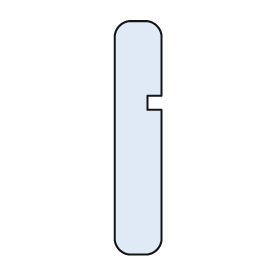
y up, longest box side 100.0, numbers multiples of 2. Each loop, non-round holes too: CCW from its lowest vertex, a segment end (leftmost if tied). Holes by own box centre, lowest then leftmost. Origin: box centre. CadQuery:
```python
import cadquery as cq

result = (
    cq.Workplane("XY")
    .moveTo(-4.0, -50.0)
    .lineTo(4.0, -50.0)
    .threePointArc((8.0, -48.0), (10.0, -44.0))
    .lineTo(10.0, 12.0)
    .lineTo(4.0, 12.0)
    .lineTo(4.0, 18.0)
    .lineTo(10.0, 18.0)
    .lineTo(10.0, 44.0)
    .threePointArc((8.0, 48.0), (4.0, 50.0))
    .lineTo(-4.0, 50.0)
    .threePointArc((-8.0, 48.0), (-10.0, 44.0))
    .lineTo(-10.0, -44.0)
    .threePointArc((-8.0, -48.0), (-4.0, -50.0))
    .close()
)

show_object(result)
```